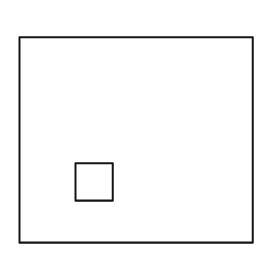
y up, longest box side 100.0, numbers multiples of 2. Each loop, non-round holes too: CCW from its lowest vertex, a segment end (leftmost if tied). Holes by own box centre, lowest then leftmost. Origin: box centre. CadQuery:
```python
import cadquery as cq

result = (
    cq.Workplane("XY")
    .moveTo(-50.0, -44.0)
    .lineTo(50.0, -44.0)
    .lineTo(50.0, 44.0)
    .lineTo(-50.0, 44.0)
    .close()
    .moveTo(-26.0, -26.0)
    .lineTo(-10.0, -26.0)
    .lineTo(-10.0, -10.0)
    .lineTo(-26.0, -10.0)
    .close()
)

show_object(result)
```